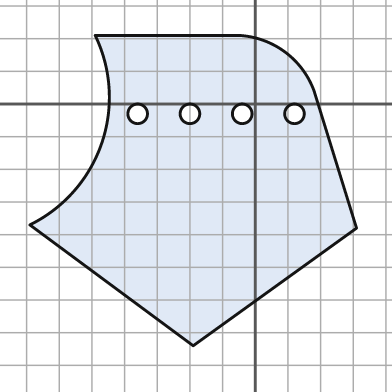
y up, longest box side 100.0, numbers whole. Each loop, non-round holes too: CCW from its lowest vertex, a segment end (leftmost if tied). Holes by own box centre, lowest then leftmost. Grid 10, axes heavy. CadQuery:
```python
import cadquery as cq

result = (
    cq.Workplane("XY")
    .moveTo(-19.0, -74.0)
    .lineTo(31.0, -38.0)
    .lineTo(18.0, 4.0)
    .threePointArc((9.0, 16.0), (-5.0, 21.0))
    .lineTo(-49.0, 21.0)
    .threePointArc((-47.0, -12.0), (-69.0, -37.0))
    .close()
    .moveTo(-36.0, -3.0)
    .circle(3.0)
    .moveTo(-20.0, -3.0)
    .circle(3.0)
    .moveTo(-4.0, -3.0)
    .circle(3.0)
    .moveTo(12.0, -3.0)
    .circle(3.0)
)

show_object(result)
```